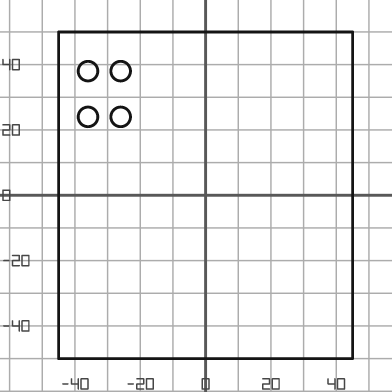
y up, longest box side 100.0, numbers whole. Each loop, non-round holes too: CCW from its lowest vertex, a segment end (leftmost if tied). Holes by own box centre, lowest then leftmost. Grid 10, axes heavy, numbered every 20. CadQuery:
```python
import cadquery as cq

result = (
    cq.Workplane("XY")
    .moveTo(-45.0, -50.0)
    .lineTo(45.0, -50.0)
    .lineTo(45.0, 50.0)
    .lineTo(-45.0, 50.0)
    .close()
    .moveTo(-36.0, 24.0)
    .circle(3.0)
    .moveTo(-26.0, 24.0)
    .circle(3.0)
    .moveTo(-36.0, 38.0)
    .circle(3.0)
    .moveTo(-26.0, 38.0)
    .circle(3.0)
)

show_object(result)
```